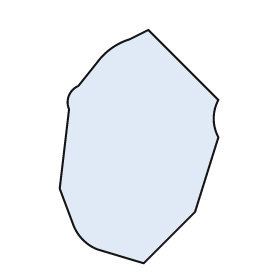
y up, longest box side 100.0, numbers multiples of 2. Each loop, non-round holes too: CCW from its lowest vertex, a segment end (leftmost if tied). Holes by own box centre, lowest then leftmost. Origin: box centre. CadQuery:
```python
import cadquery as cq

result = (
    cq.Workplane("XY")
    .moveTo(2.0, -50.0)
    .lineTo(24.0, -28.0)
    .lineTo(34.0, 4.0)
    .threePointArc((32.0, 12.0), (34.0, 20.0))
    .lineTo(4.0, 50.0)
    .lineTo(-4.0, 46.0)
    .threePointArc((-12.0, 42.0), (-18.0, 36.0))
    .lineTo(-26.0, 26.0)
    .threePointArc((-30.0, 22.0), (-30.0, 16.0))
    .lineTo(-34.0, -18.0)
    .lineTo(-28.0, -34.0)
    .threePointArc((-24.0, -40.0), (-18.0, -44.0))
    .close()
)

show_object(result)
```